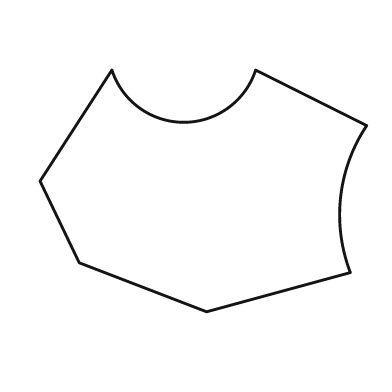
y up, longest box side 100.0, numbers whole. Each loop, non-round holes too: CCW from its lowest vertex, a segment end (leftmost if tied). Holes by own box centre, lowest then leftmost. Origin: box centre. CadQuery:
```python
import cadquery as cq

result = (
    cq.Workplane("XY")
    .moveTo(1.0, -37.0)
    .lineTo(45.0, -25.0)
    .threePointArc((42.0, -2.0), (50.0, 20.0))
    .lineTo(16.0, 37.0)
    .threePointArc((-6.0, 21.0), (-28.0, 37.0))
    .lineTo(-50.0, 3.0)
    .lineTo(-38.0, -22.0)
    .close()
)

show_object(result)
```